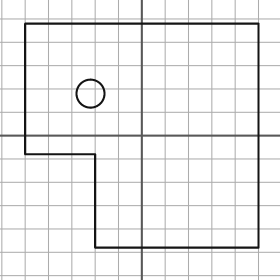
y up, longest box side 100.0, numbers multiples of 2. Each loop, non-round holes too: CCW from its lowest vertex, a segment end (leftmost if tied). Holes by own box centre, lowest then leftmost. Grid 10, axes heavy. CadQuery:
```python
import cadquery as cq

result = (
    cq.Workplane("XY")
    .moveTo(-20.0, -48.0)
    .lineTo(50.0, -48.0)
    .lineTo(50.0, 48.0)
    .lineTo(-50.0, 48.0)
    .lineTo(-50.0, -8.0)
    .lineTo(-20.0, -8.0)
    .close()
    .moveTo(-22.0, 18.0)
    .circle(6.0)
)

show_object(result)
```